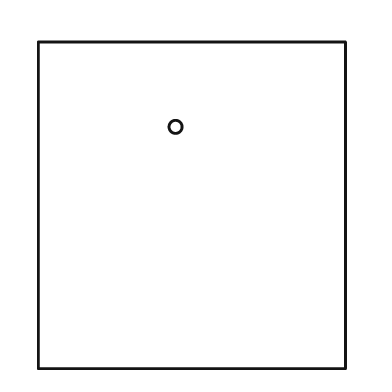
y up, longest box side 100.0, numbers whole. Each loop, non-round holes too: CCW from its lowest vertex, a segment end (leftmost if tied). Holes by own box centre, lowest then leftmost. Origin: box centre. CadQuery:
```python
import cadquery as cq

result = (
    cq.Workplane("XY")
    .moveTo(-47.0, -50.0)
    .lineTo(47.0, -50.0)
    .lineTo(47.0, 50.0)
    .lineTo(-47.0, 50.0)
    .close()
    .moveTo(-5.0, 24.0)
    .circle(2.0)
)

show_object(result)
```